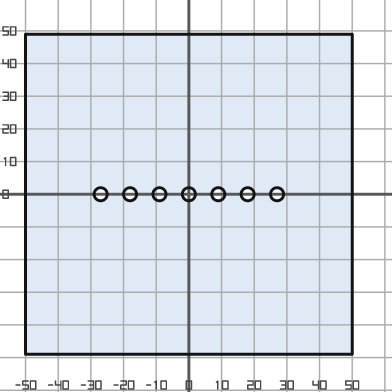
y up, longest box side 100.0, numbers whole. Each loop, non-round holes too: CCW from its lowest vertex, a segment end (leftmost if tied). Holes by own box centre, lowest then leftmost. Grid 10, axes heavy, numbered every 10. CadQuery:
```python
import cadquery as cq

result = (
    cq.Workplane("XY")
    .moveTo(-50.0, -49.0)
    .lineTo(50.0, -49.0)
    .lineTo(50.0, 49.0)
    .lineTo(-50.0, 49.0)
    .close()
    .moveTo(-27.0, 0.0)
    .circle(2.0)
    .moveTo(-18.0, 0.0)
    .circle(2.0)
    .moveTo(-9.0, 0.0)
    .circle(2.0)
    .moveTo(0.0, 0.0)
    .circle(2.0)
    .moveTo(9.0, 0.0)
    .circle(2.0)
    .moveTo(18.0, 0.0)
    .circle(2.0)
    .moveTo(27.0, 0.0)
    .circle(2.0)
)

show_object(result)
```